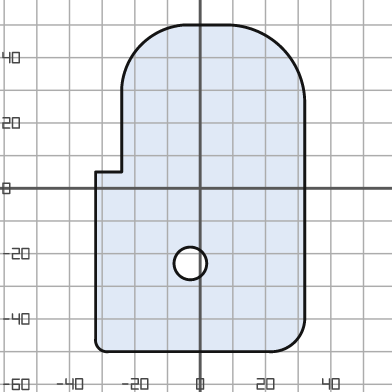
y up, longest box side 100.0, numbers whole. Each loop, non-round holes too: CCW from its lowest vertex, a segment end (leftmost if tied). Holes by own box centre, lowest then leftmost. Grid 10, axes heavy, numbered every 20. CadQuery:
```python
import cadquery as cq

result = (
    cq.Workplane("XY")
    .moveTo(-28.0, -50.0)
    .lineTo(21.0, -50.0)
    .threePointArc((29.0, -47.0), (32.0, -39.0))
    .lineTo(32.0, 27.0)
    .threePointArc((25.0, 43.0), (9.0, 50.0))
    .lineTo(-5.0, 50.0)
    .threePointArc((-18.0, 44.0), (-24.0, 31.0))
    .lineTo(-24.0, 5.0)
    .lineTo(-32.0, 5.0)
    .lineTo(-32.0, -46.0)
    .threePointArc((-31.0, -49.0), (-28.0, -50.0))
    .close()
    .moveTo(-3.0, -23.0)
    .circle(5.0)
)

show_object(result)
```